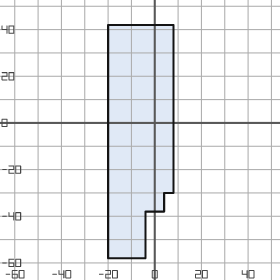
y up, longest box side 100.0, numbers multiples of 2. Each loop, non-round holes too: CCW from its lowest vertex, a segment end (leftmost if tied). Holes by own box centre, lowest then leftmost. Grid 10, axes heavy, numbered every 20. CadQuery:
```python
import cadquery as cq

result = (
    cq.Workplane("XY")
    .moveTo(-20.0, -58.0)
    .lineTo(-4.0, -58.0)
    .lineTo(-4.0, -38.0)
    .lineTo(4.0, -38.0)
    .lineTo(4.0, -30.0)
    .lineTo(8.0, -30.0)
    .lineTo(8.0, 42.0)
    .lineTo(-20.0, 42.0)
    .close()
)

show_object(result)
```